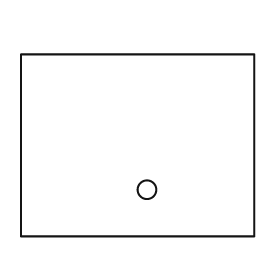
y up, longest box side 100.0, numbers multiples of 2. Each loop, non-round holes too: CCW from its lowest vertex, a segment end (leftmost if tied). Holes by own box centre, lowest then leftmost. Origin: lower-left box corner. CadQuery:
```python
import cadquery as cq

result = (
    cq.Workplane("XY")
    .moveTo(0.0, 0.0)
    .lineTo(100.0, 0.0)
    .lineTo(100.0, 78.0)
    .lineTo(0.0, 78.0)
    .close()
    .moveTo(54.0, 20.0)
    .circle(4.0)
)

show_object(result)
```